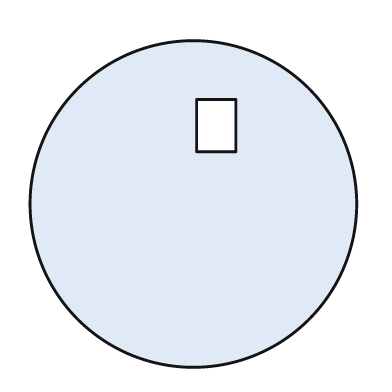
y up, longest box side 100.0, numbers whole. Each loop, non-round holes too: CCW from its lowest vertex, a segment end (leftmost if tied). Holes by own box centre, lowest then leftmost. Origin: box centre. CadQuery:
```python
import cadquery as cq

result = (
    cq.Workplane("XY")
    .moveTo(0.0, 0.0)
    .circle(50.0)
    .moveTo(1.0, 16.0)
    .lineTo(13.0, 16.0)
    .lineTo(13.0, 32.0)
    .lineTo(1.0, 32.0)
    .close()
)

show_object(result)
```